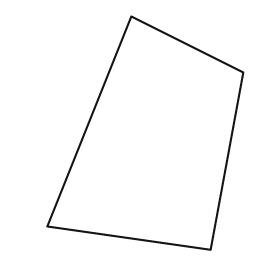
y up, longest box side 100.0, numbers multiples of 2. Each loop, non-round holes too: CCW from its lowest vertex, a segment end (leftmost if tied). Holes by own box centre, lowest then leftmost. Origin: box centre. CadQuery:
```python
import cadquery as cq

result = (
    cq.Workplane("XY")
    .moveTo(28.0, -50.0)
    .lineTo(42.0, 26.0)
    .lineTo(-6.0, 50.0)
    .lineTo(-42.0, -40.0)
    .close()
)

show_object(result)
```